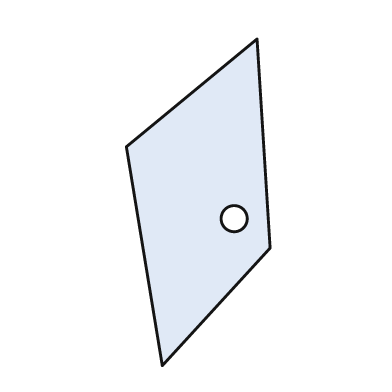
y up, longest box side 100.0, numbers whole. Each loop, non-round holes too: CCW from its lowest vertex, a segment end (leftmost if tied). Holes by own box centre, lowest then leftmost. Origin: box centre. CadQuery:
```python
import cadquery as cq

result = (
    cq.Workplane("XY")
    .moveTo(-11.0, -50.0)
    .lineTo(22.0, -14.0)
    .lineTo(18.0, 50.0)
    .lineTo(-22.0, 17.0)
    .close()
    .moveTo(11.0, -5.0)
    .circle(4.0)
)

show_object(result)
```